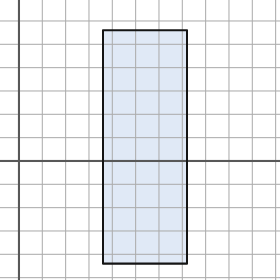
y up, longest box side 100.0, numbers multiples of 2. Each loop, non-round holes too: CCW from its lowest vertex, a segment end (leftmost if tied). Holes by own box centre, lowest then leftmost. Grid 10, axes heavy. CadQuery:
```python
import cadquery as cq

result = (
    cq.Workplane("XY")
    .moveTo(36.0, -44.0)
    .lineTo(72.0, -44.0)
    .lineTo(72.0, 56.0)
    .lineTo(36.0, 56.0)
    .close()
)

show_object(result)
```